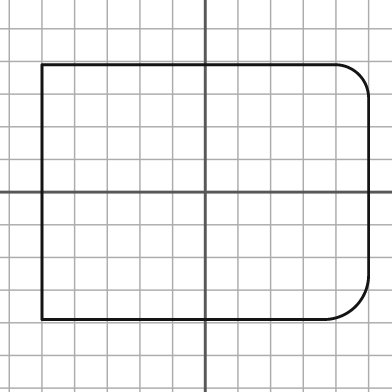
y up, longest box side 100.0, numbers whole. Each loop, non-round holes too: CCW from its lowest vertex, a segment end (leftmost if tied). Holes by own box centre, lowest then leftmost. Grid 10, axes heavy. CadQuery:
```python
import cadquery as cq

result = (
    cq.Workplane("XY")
    .moveTo(-50.0, -39.0)
    .lineTo(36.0, -39.0)
    .threePointArc((46.0, -35.0), (50.0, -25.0))
    .lineTo(50.0, 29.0)
    .threePointArc((47.0, 36.0), (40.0, 39.0))
    .lineTo(-50.0, 39.0)
    .close()
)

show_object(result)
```